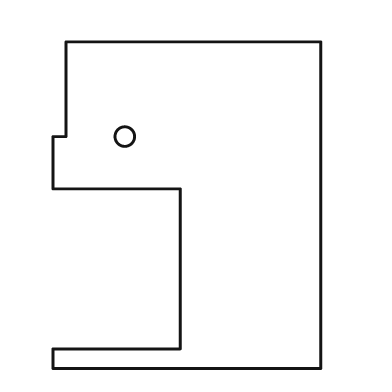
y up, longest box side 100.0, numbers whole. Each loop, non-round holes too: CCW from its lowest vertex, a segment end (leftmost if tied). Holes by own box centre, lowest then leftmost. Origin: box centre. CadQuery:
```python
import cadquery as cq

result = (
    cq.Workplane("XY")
    .moveTo(-41.0, -50.0)
    .lineTo(41.0, -50.0)
    .lineTo(41.0, 50.0)
    .lineTo(-37.0, 50.0)
    .lineTo(-37.0, 21.0)
    .lineTo(-41.0, 21.0)
    .lineTo(-41.0, 5.0)
    .lineTo(-2.0, 5.0)
    .lineTo(-2.0, -44.0)
    .lineTo(-41.0, -44.0)
    .close()
    .moveTo(-19.0, 21.0)
    .circle(3.0)
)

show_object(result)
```